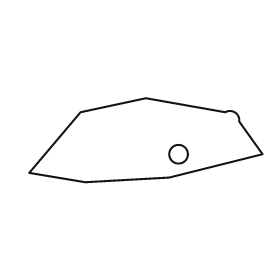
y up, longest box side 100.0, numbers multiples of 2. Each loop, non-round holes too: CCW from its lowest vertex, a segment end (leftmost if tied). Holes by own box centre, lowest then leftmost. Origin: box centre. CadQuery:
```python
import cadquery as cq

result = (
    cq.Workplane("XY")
    .moveTo(-26.0, -18.0)
    .lineTo(10.0, -16.0)
    .lineTo(50.0, -6.0)
    .lineTo(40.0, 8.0)
    .threePointArc((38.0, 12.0), (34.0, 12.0))
    .lineTo(0.0, 18.0)
    .lineTo(-28.0, 12.0)
    .lineTo(-50.0, -14.0)
    .close()
    .moveTo(14.0, -6.0)
    .circle(4.0)
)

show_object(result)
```